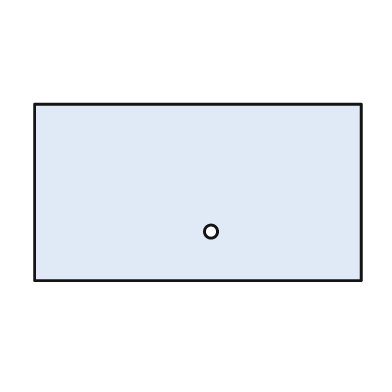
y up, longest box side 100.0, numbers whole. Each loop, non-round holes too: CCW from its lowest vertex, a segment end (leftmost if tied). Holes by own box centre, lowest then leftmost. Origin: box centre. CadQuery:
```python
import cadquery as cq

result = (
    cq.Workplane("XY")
    .moveTo(-50.0, -27.0)
    .lineTo(50.0, -27.0)
    .lineTo(50.0, 27.0)
    .lineTo(-50.0, 27.0)
    .close()
    .moveTo(4.0, -12.0)
    .circle(2.0)
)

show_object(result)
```